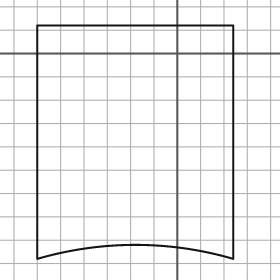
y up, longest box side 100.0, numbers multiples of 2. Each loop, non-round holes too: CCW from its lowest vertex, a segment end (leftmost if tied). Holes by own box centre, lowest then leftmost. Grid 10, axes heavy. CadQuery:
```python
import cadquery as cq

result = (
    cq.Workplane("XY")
    .moveTo(-60.0, -88.0)
    .threePointArc((-18.0, -82.0), (24.0, -88.0))
    .lineTo(24.0, 12.0)
    .lineTo(-60.0, 12.0)
    .close()
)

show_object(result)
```